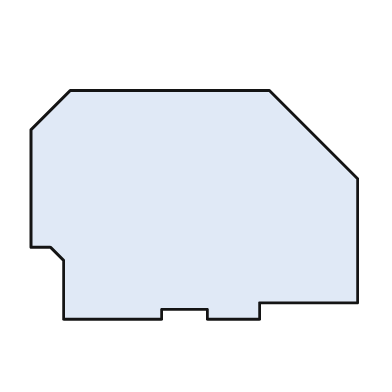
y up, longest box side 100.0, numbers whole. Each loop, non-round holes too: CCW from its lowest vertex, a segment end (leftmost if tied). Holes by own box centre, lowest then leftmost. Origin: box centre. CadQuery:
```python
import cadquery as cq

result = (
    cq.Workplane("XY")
    .moveTo(-40.0, -35.0)
    .lineTo(-10.0, -35.0)
    .lineTo(-10.0, -32.0)
    .lineTo(4.0, -32.0)
    .lineTo(4.0, -35.0)
    .lineTo(20.0, -35.0)
    .lineTo(20.0, -30.0)
    .lineTo(50.0, -30.0)
    .lineTo(50.0, 8.0)
    .lineTo(23.0, 35.0)
    .lineTo(-38.0, 35.0)
    .lineTo(-50.0, 23.0)
    .lineTo(-50.0, -13.0)
    .lineTo(-44.0, -13.0)
    .lineTo(-40.0, -17.0)
    .close()
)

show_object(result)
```